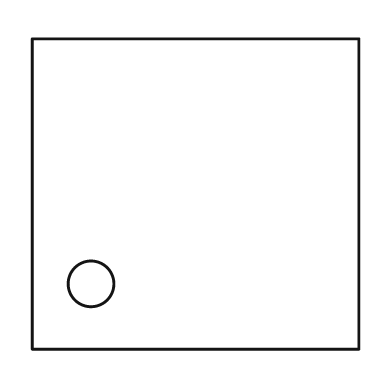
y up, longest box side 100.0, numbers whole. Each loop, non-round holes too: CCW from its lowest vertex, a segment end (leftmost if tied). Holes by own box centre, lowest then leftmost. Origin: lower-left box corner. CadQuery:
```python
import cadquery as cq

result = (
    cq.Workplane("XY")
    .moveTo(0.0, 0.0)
    .lineTo(100.0, 0.0)
    .lineTo(100.0, 95.0)
    .lineTo(0.0, 95.0)
    .close()
    .moveTo(18.0, 20.0)
    .circle(7.0)
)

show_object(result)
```